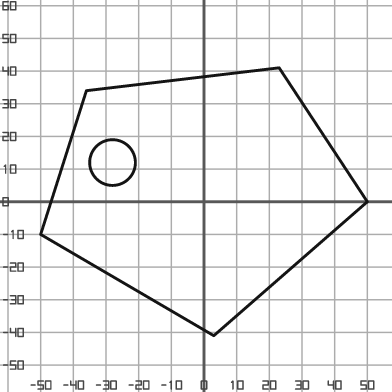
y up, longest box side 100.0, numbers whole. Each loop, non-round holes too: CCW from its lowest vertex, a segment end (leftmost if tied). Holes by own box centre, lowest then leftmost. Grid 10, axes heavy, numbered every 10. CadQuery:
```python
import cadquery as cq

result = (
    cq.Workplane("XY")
    .moveTo(3.0, -41.0)
    .lineTo(50.0, 0.0)
    .lineTo(23.0, 41.0)
    .lineTo(-36.0, 34.0)
    .lineTo(-50.0, -10.0)
    .close()
    .moveTo(-28.0, 12.0)
    .circle(7.0)
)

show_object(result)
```